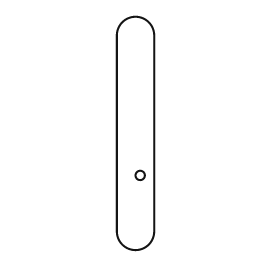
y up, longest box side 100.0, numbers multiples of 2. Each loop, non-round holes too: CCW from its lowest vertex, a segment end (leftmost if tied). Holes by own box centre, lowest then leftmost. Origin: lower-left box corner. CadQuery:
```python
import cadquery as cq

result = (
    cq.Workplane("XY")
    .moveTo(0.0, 8.0)
    .threePointArc((8.0, 0.0), (16.0, 8.0))
    .lineTo(16.0, 92.0)
    .threePointArc((8.0, 100.0), (0.0, 92.0))
    .close()
    .moveTo(10.0, 32.0)
    .circle(2.0)
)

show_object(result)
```